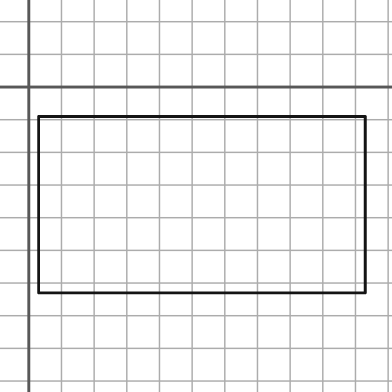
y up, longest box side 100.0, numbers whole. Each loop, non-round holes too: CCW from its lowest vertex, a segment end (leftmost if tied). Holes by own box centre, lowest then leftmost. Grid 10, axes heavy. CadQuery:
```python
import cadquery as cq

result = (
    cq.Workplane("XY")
    .moveTo(3.0, -63.0)
    .lineTo(103.0, -63.0)
    .lineTo(103.0, -9.0)
    .lineTo(3.0, -9.0)
    .close()
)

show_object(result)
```